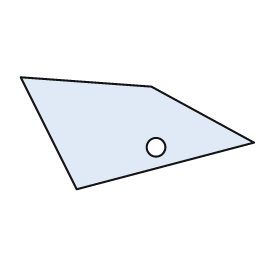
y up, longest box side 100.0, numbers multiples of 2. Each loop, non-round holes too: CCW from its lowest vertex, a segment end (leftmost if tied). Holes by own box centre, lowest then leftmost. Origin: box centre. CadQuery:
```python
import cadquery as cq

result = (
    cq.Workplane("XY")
    .moveTo(-26.0, -24.0)
    .lineTo(50.0, -4.0)
    .lineTo(6.0, 20.0)
    .lineTo(-50.0, 24.0)
    .close()
    .moveTo(8.0, -6.0)
    .circle(4.0)
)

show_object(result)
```